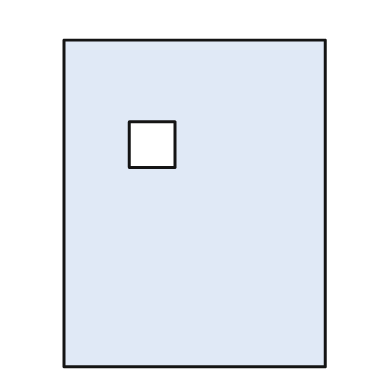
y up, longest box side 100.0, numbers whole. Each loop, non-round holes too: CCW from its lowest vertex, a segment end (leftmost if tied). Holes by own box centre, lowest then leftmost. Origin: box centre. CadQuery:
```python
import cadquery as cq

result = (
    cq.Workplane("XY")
    .moveTo(-40.0, -50.0)
    .lineTo(40.0, -50.0)
    .lineTo(40.0, 50.0)
    .lineTo(-40.0, 50.0)
    .close()
    .moveTo(-20.0, 11.0)
    .lineTo(-6.0, 11.0)
    .lineTo(-6.0, 25.0)
    .lineTo(-20.0, 25.0)
    .close()
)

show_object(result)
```